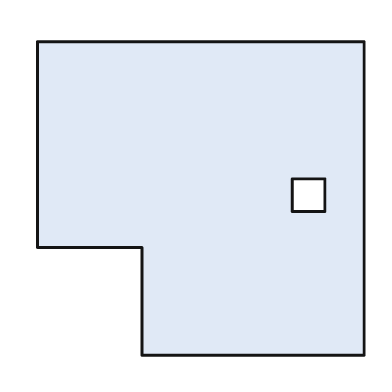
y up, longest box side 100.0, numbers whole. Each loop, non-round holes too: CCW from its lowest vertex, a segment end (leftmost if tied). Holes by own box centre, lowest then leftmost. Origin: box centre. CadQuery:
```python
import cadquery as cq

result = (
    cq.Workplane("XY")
    .moveTo(-18.0, -48.0)
    .lineTo(50.0, -48.0)
    .lineTo(50.0, 48.0)
    .lineTo(-50.0, 48.0)
    .lineTo(-50.0, -15.0)
    .lineTo(-18.0, -15.0)
    .close()
    .moveTo(28.0, -4.0)
    .lineTo(38.0, -4.0)
    .lineTo(38.0, 6.0)
    .lineTo(28.0, 6.0)
    .close()
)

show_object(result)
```